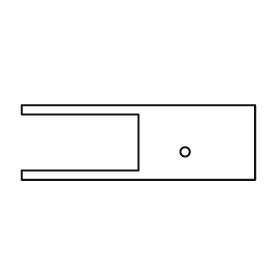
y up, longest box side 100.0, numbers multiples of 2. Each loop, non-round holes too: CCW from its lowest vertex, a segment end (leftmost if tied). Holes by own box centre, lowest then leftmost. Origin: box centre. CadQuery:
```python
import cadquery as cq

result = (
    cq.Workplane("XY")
    .moveTo(-50.0, -16.0)
    .lineTo(50.0, -16.0)
    .lineTo(50.0, 16.0)
    .lineTo(-50.0, 16.0)
    .lineTo(-50.0, 12.0)
    .lineTo(0.0, 12.0)
    .lineTo(0.0, -12.0)
    .lineTo(-50.0, -12.0)
    .close()
    .moveTo(20.0, -4.0)
    .circle(2.0)
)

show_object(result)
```